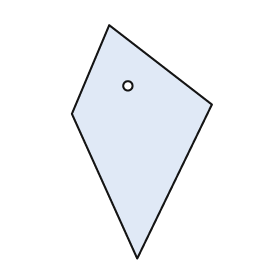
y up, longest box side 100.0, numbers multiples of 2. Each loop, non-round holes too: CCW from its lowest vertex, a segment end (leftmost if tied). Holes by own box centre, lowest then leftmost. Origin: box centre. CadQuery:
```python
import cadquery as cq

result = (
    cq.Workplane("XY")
    .moveTo(-2.0, -50.0)
    .lineTo(30.0, 16.0)
    .lineTo(-14.0, 50.0)
    .lineTo(-30.0, 12.0)
    .close()
    .moveTo(-6.0, 24.0)
    .circle(2.0)
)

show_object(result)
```